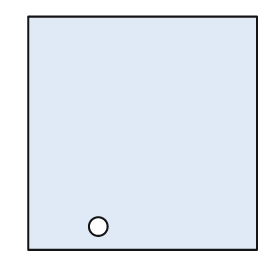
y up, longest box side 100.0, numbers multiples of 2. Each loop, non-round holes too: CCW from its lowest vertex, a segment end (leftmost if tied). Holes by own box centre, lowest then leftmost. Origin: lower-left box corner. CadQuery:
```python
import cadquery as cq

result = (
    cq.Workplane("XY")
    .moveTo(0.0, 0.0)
    .lineTo(98.0, 0.0)
    .lineTo(98.0, 100.0)
    .lineTo(0.0, 100.0)
    .close()
    .moveTo(30.0, 10.0)
    .circle(4.0)
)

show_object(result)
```